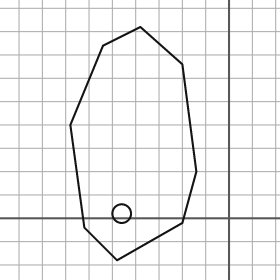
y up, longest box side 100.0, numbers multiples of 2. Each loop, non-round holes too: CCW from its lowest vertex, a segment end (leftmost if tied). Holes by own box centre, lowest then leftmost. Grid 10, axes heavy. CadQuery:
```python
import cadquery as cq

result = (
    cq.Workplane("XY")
    .moveTo(-48.0, -18.0)
    .lineTo(-20.0, -2.0)
    .lineTo(-14.0, 20.0)
    .lineTo(-20.0, 66.0)
    .lineTo(-38.0, 82.0)
    .lineTo(-54.0, 74.0)
    .lineTo(-68.0, 40.0)
    .lineTo(-62.0, -4.0)
    .close()
    .moveTo(-46.0, 2.0)
    .circle(4.0)
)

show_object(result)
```